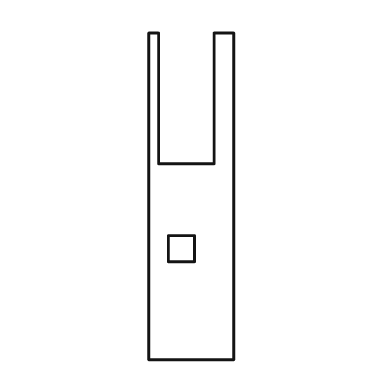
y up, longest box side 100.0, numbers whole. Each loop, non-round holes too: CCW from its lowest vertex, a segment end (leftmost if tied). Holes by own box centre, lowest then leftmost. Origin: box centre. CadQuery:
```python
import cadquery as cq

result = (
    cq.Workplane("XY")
    .moveTo(-13.0, -50.0)
    .lineTo(13.0, -50.0)
    .lineTo(13.0, 50.0)
    .lineTo(7.0, 50.0)
    .lineTo(7.0, 10.0)
    .lineTo(-10.0, 10.0)
    .lineTo(-10.0, 50.0)
    .lineTo(-13.0, 50.0)
    .close()
    .moveTo(-7.0, -20.0)
    .lineTo(1.0, -20.0)
    .lineTo(1.0, -12.0)
    .lineTo(-7.0, -12.0)
    .close()
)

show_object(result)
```